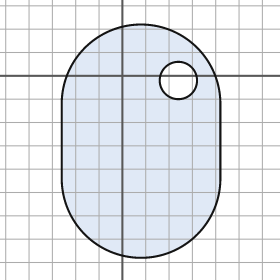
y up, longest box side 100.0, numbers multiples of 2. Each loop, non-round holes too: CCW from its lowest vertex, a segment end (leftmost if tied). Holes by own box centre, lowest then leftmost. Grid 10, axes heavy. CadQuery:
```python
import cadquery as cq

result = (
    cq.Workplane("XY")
    .moveTo(-26.0, -44.0)
    .threePointArc((8.0, -78.0), (42.0, -44.0))
    .lineTo(42.0, -12.0)
    .threePointArc((8.0, 22.0), (-26.0, -12.0))
    .close()
    .moveTo(24.0, -2.0)
    .circle(8.0)
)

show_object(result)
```